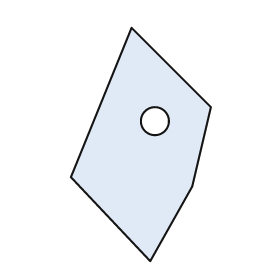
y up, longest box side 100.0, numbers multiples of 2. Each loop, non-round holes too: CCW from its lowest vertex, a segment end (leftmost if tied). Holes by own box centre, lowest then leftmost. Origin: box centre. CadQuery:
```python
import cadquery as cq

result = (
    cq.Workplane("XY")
    .moveTo(4.0, -50.0)
    .lineTo(22.0, -18.0)
    .lineTo(30.0, 16.0)
    .lineTo(-4.0, 50.0)
    .lineTo(-30.0, -14.0)
    .close()
    .moveTo(6.0, 10.0)
    .circle(6.0)
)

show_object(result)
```